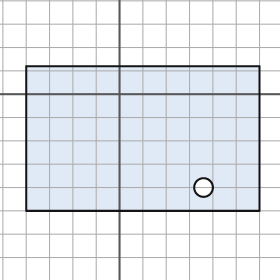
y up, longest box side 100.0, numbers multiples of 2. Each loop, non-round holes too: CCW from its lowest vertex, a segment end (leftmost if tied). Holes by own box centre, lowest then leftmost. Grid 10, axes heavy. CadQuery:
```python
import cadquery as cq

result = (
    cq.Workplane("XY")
    .moveTo(-40.0, -50.0)
    .lineTo(60.0, -50.0)
    .lineTo(60.0, 12.0)
    .lineTo(-40.0, 12.0)
    .close()
    .moveTo(36.0, -40.0)
    .circle(4.0)
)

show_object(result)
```